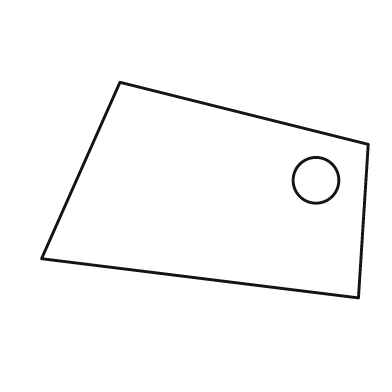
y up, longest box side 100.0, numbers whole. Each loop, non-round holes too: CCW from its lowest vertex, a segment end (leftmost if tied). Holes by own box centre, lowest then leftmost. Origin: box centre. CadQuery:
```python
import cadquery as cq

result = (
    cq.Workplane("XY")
    .moveTo(47.0, -33.0)
    .lineTo(50.0, 14.0)
    .lineTo(-26.0, 33.0)
    .lineTo(-50.0, -21.0)
    .close()
    .moveTo(34.0, 3.0)
    .circle(7.0)
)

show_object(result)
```